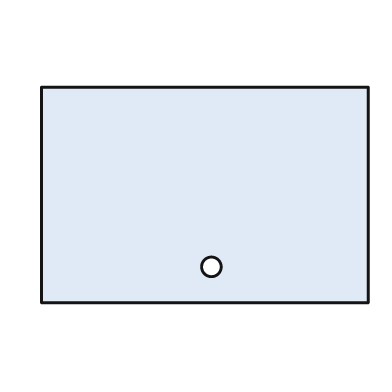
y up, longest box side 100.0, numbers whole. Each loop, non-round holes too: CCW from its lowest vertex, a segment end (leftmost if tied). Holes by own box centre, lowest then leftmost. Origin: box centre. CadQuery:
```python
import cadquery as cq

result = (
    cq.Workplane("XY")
    .moveTo(-50.0, -33.0)
    .lineTo(50.0, -33.0)
    .lineTo(50.0, 33.0)
    .lineTo(-50.0, 33.0)
    .close()
    .moveTo(2.0, -22.0)
    .circle(3.0)
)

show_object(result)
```